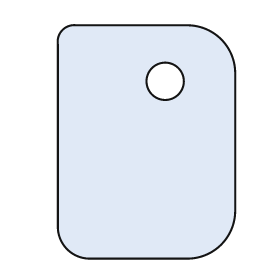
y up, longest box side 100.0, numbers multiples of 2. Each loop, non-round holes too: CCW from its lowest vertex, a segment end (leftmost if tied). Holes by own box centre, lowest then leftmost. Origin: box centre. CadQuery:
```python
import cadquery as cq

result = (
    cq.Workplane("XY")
    .moveTo(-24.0, -50.0)
    .lineTo(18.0, -50.0)
    .threePointArc((32.0, -44.0), (38.0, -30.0))
    .lineTo(38.0, 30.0)
    .threePointArc((32.0, 44.0), (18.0, 50.0))
    .lineTo(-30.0, 50.0)
    .threePointArc((-36.0, 48.0), (-38.0, 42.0))
    .lineTo(-38.0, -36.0)
    .threePointArc((-34.0, -46.0), (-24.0, -50.0))
    .close()
    .moveTo(8.0, 26.0)
    .circle(8.0)
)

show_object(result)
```